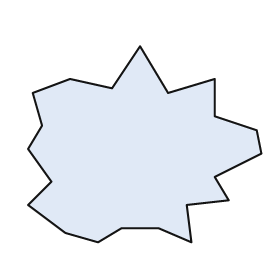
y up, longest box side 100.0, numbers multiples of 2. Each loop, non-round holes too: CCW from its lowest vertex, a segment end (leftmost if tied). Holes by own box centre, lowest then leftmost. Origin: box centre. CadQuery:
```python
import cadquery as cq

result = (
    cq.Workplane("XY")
    .moveTo(-20.0, -42.0)
    .lineTo(-10.0, -36.0)
    .lineTo(6.0, -36.0)
    .lineTo(20.0, -42.0)
    .lineTo(18.0, -26.0)
    .lineTo(36.0, -24.0)
    .lineTo(30.0, -14.0)
    .lineTo(50.0, -4.0)
    .lineTo(48.0, 6.0)
    .lineTo(30.0, 12.0)
    .lineTo(30.0, 28.0)
    .lineTo(10.0, 22.0)
    .lineTo(-2.0, 42.0)
    .lineTo(-14.0, 24.0)
    .lineTo(-32.0, 28.0)
    .lineTo(-48.0, 22.0)
    .lineTo(-44.0, 8.0)
    .lineTo(-50.0, -2.0)
    .lineTo(-40.0, -16.0)
    .lineTo(-50.0, -26.0)
    .lineTo(-34.0, -38.0)
    .close()
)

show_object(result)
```